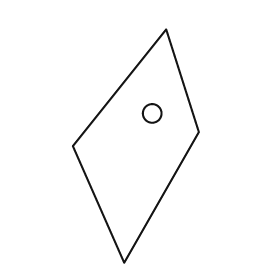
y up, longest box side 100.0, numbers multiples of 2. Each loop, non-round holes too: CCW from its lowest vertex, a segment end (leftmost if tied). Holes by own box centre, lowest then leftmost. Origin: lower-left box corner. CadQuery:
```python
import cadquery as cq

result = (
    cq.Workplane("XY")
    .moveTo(22.0, 0.0)
    .lineTo(54.0, 56.0)
    .lineTo(40.0, 100.0)
    .lineTo(0.0, 50.0)
    .close()
    .moveTo(34.0, 64.0)
    .circle(4.0)
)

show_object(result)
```